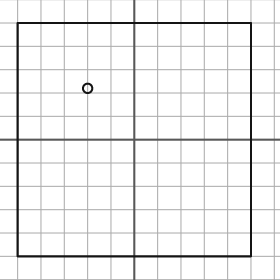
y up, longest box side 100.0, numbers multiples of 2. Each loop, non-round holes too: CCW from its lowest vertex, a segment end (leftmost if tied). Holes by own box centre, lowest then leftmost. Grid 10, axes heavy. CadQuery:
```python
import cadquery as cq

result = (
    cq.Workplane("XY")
    .moveTo(-50.0, -50.0)
    .lineTo(50.0, -50.0)
    .lineTo(50.0, 50.0)
    .lineTo(-50.0, 50.0)
    .close()
    .moveTo(-20.0, 22.0)
    .circle(2.0)
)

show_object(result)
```